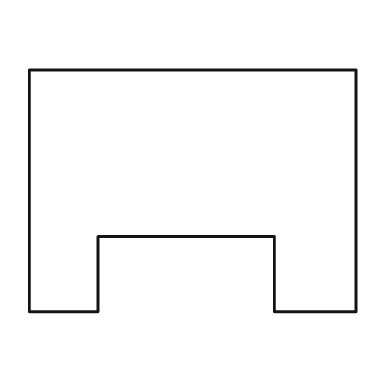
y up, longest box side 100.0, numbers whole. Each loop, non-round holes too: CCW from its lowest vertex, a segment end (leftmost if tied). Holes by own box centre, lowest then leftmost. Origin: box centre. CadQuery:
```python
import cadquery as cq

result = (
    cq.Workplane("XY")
    .moveTo(-50.0, -37.0)
    .lineTo(-29.0, -37.0)
    .lineTo(-29.0, -14.0)
    .lineTo(25.0, -14.0)
    .lineTo(25.0, -37.0)
    .lineTo(50.0, -37.0)
    .lineTo(50.0, 37.0)
    .lineTo(-50.0, 37.0)
    .close()
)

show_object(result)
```